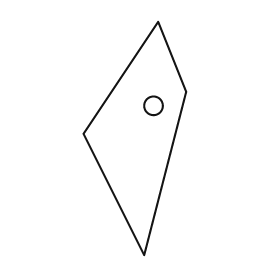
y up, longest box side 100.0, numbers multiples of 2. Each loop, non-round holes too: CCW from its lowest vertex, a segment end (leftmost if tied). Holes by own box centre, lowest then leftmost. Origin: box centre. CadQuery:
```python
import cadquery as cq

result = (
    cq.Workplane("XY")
    .moveTo(4.0, -50.0)
    .lineTo(22.0, 20.0)
    .lineTo(10.0, 50.0)
    .lineTo(-22.0, 2.0)
    .close()
    .moveTo(8.0, 14.0)
    .circle(4.0)
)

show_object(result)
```